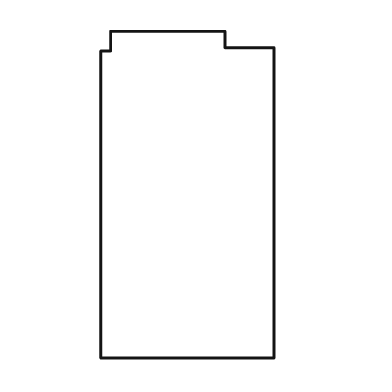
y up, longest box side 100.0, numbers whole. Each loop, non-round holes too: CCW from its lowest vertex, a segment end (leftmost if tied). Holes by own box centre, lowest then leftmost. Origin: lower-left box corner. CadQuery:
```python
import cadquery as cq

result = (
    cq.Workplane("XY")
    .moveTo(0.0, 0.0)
    .lineTo(53.0, 0.0)
    .lineTo(53.0, 95.0)
    .lineTo(38.0, 95.0)
    .lineTo(38.0, 100.0)
    .lineTo(3.0, 100.0)
    .lineTo(3.0, 94.0)
    .lineTo(0.0, 94.0)
    .close()
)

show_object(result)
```